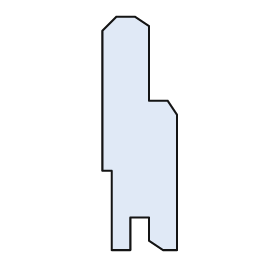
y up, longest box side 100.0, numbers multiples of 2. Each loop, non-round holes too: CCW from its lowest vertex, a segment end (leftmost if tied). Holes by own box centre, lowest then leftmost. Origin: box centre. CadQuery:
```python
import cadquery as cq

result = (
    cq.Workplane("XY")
    .moveTo(-12.0, -50.0)
    .lineTo(-4.0, -50.0)
    .lineTo(-4.0, -36.0)
    .lineTo(4.0, -36.0)
    .lineTo(4.0, -46.0)
    .lineTo(10.0, -50.0)
    .lineTo(16.0, -50.0)
    .lineTo(16.0, 8.0)
    .lineTo(12.0, 14.0)
    .lineTo(4.0, 14.0)
    .lineTo(4.0, 46.0)
    .lineTo(-2.0, 50.0)
    .lineTo(-10.0, 50.0)
    .lineTo(-16.0, 44.0)
    .lineTo(-16.0, -16.0)
    .lineTo(-12.0, -16.0)
    .close()
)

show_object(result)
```